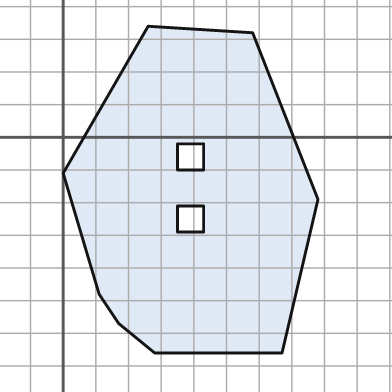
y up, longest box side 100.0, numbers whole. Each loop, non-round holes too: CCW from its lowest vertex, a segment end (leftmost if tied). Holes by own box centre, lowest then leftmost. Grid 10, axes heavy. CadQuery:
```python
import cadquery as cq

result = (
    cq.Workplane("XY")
    .moveTo(28.0, -66.0)
    .lineTo(67.0, -66.0)
    .lineTo(78.0, -19.0)
    .lineTo(58.0, 32.0)
    .lineTo(26.0, 34.0)
    .lineTo(0.0, -11.0)
    .lineTo(11.0, -48.0)
    .lineTo(17.0, -57.0)
    .close()
    .moveTo(35.0, -29.0)
    .lineTo(43.0, -29.0)
    .lineTo(43.0, -21.0)
    .lineTo(35.0, -21.0)
    .close()
    .moveTo(35.0, -10.0)
    .lineTo(43.0, -10.0)
    .lineTo(43.0, -2.0)
    .lineTo(35.0, -2.0)
    .close()
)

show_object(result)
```